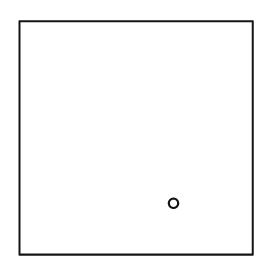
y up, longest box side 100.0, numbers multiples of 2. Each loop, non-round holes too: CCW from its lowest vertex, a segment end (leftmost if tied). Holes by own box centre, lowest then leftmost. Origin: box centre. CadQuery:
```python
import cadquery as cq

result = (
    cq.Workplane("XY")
    .moveTo(-50.0, -50.0)
    .lineTo(50.0, -50.0)
    .lineTo(50.0, 50.0)
    .lineTo(-50.0, 50.0)
    .close()
    .moveTo(16.0, -28.0)
    .circle(2.0)
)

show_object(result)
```